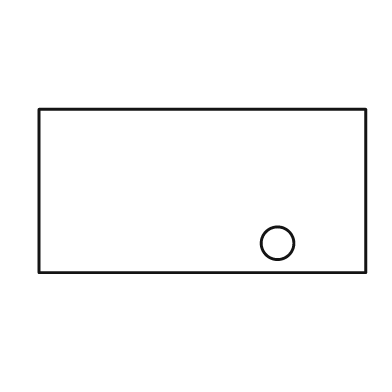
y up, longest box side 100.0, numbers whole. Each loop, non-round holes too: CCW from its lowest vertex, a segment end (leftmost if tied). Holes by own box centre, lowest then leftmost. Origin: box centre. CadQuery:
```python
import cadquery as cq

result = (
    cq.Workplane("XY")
    .moveTo(-50.0, -25.0)
    .lineTo(50.0, -25.0)
    .lineTo(50.0, 25.0)
    .lineTo(-50.0, 25.0)
    .close()
    .moveTo(23.0, -16.0)
    .circle(5.0)
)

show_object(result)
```